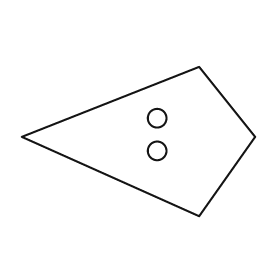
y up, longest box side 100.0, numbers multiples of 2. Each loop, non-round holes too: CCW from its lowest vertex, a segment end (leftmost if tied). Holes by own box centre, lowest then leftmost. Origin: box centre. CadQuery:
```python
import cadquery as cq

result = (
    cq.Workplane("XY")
    .moveTo(26.0, -32.0)
    .lineTo(50.0, 2.0)
    .lineTo(26.0, 32.0)
    .lineTo(-50.0, 2.0)
    .close()
    .moveTo(8.0, -4.0)
    .circle(4.0)
    .moveTo(8.0, 10.0)
    .circle(4.0)
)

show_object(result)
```